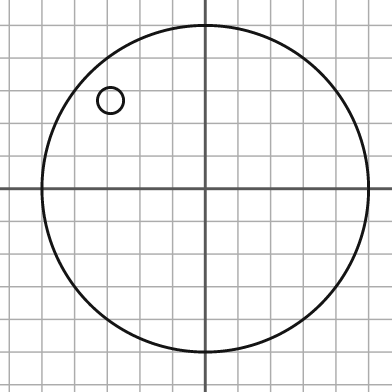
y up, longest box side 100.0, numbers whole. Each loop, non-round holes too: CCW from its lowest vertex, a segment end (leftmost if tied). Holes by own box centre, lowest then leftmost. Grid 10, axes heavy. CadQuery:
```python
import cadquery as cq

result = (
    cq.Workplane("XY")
    .moveTo(0.0, 0.0)
    .circle(50.0)
    .moveTo(-29.0, 27.0)
    .circle(4.0)
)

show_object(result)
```